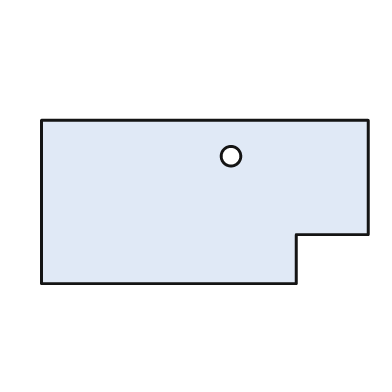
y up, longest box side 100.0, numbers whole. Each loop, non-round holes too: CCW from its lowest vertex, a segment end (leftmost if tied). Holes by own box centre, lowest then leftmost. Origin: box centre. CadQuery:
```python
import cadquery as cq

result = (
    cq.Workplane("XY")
    .moveTo(-50.0, -25.0)
    .lineTo(28.0, -25.0)
    .lineTo(28.0, -10.0)
    .lineTo(50.0, -10.0)
    .lineTo(50.0, 25.0)
    .lineTo(-50.0, 25.0)
    .close()
    .moveTo(8.0, 14.0)
    .circle(3.0)
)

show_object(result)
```